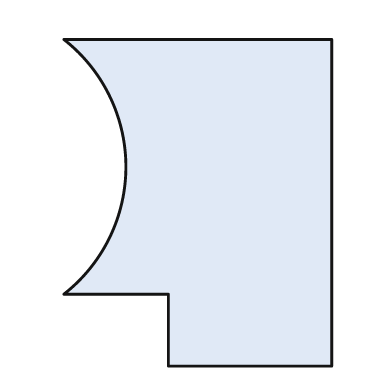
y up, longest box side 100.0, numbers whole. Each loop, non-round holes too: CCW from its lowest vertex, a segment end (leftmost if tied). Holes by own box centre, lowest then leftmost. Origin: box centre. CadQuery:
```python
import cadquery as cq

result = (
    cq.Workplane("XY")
    .moveTo(-9.0, -50.0)
    .lineTo(41.0, -50.0)
    .lineTo(41.0, 50.0)
    .lineTo(-41.0, 50.0)
    .threePointArc((-22.0, 11.0), (-41.0, -28.0))
    .lineTo(-9.0, -28.0)
    .close()
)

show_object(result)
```